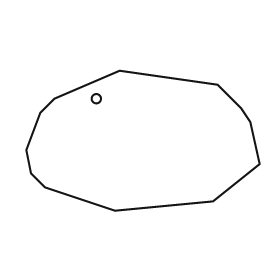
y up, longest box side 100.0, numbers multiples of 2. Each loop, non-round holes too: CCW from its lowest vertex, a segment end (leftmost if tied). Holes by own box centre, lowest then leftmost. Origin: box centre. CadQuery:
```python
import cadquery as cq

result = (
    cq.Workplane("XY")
    .moveTo(-12.0, -30.0)
    .lineTo(30.0, -26.0)
    .lineTo(50.0, -10.0)
    .lineTo(46.0, 8.0)
    .lineTo(42.0, 14.0)
    .lineTo(32.0, 24.0)
    .lineTo(-10.0, 30.0)
    .lineTo(-38.0, 18.0)
    .lineTo(-44.0, 12.0)
    .lineTo(-50.0, -4.0)
    .lineTo(-48.0, -14.0)
    .lineTo(-42.0, -20.0)
    .close()
    .moveTo(-20.0, 18.0)
    .circle(2.0)
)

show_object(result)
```